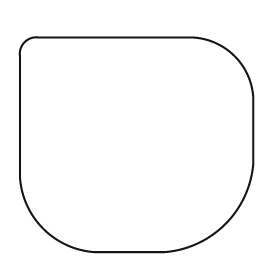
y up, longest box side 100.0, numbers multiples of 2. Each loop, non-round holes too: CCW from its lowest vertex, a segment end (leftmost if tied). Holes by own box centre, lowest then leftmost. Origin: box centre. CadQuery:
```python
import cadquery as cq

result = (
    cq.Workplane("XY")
    .moveTo(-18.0, -46.0)
    .lineTo(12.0, -46.0)
    .threePointArc((38.0, -34.0), (50.0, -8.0))
    .lineTo(50.0, 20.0)
    .threePointArc((42.0, 38.0), (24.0, 46.0))
    .lineTo(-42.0, 46.0)
    .threePointArc((-48.0, 44.0), (-50.0, 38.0))
    .lineTo(-50.0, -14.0)
    .threePointArc((-40.0, -36.0), (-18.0, -46.0))
    .close()
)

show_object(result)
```